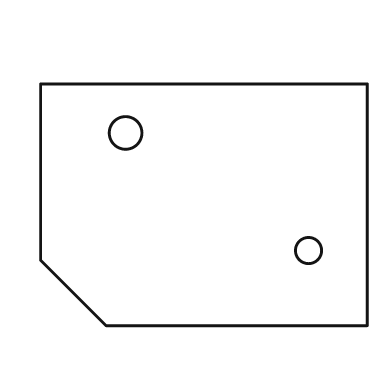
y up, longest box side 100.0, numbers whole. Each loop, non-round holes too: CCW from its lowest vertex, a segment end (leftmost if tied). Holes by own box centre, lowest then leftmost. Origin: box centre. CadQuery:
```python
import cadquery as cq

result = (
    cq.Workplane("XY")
    .moveTo(-30.0, -37.0)
    .lineTo(50.0, -37.0)
    .lineTo(50.0, 37.0)
    .lineTo(-50.0, 37.0)
    .lineTo(-50.0, -17.0)
    .close()
    .moveTo(32.0, -14.0)
    .circle(4.0)
    .moveTo(-24.0, 22.0)
    .circle(5.0)
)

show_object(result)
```